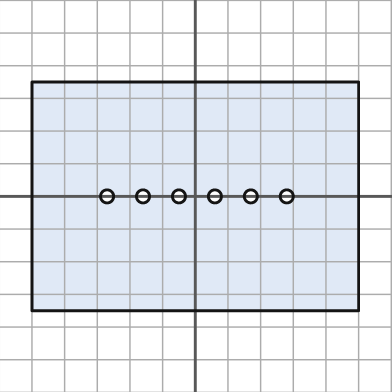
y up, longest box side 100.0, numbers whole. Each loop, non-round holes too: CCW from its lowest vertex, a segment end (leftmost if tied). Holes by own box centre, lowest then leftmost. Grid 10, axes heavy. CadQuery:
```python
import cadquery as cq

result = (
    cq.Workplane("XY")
    .moveTo(-50.0, -35.0)
    .lineTo(50.0, -35.0)
    .lineTo(50.0, 35.0)
    .lineTo(-50.0, 35.0)
    .close()
    .moveTo(-27.0, 0.0)
    .circle(2.0)
    .moveTo(-16.0, 0.0)
    .circle(2.0)
    .moveTo(-5.0, 0.0)
    .circle(2.0)
    .moveTo(6.0, 0.0)
    .circle(2.0)
    .moveTo(17.0, 0.0)
    .circle(2.0)
    .moveTo(28.0, 0.0)
    .circle(2.0)
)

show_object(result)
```